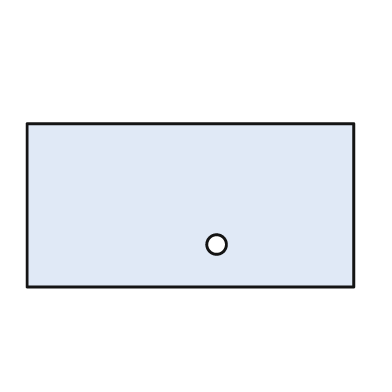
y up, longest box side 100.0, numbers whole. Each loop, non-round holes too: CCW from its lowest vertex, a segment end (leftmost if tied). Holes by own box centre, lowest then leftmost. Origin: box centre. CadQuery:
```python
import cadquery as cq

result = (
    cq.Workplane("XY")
    .moveTo(-50.0, -25.0)
    .lineTo(50.0, -25.0)
    .lineTo(50.0, 25.0)
    .lineTo(-50.0, 25.0)
    .close()
    .moveTo(8.0, -12.0)
    .circle(3.0)
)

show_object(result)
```